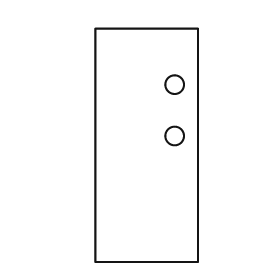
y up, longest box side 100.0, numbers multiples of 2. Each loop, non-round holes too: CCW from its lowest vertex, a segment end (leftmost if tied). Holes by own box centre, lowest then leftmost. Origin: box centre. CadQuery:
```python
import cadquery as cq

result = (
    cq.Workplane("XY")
    .moveTo(-22.0, -50.0)
    .lineTo(22.0, -50.0)
    .lineTo(22.0, 50.0)
    .lineTo(-22.0, 50.0)
    .close()
    .moveTo(12.0, 4.0)
    .circle(4.0)
    .moveTo(12.0, 26.0)
    .circle(4.0)
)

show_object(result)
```